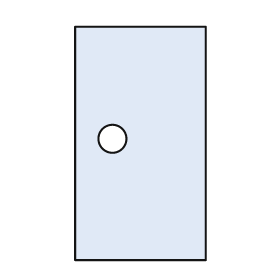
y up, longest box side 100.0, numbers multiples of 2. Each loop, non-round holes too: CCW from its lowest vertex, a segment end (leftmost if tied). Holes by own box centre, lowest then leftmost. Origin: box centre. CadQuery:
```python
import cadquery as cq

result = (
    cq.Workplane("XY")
    .moveTo(-28.0, -50.0)
    .lineTo(28.0, -50.0)
    .lineTo(28.0, 50.0)
    .lineTo(-28.0, 50.0)
    .close()
    .moveTo(-12.0, 2.0)
    .circle(6.0)
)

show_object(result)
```